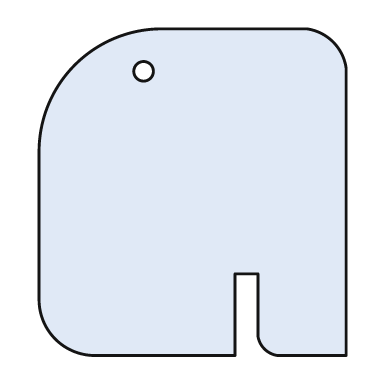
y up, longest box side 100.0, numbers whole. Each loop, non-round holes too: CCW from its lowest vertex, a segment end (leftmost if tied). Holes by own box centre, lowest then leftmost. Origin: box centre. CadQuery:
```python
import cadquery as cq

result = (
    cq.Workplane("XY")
    .moveTo(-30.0, -50.0)
    .lineTo(13.0, -50.0)
    .lineTo(13.0, -25.0)
    .lineTo(20.0, -25.0)
    .lineTo(20.0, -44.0)
    .threePointArc((22.0, -48.0), (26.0, -50.0))
    .lineTo(47.0, -50.0)
    .lineTo(47.0, 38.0)
    .threePointArc((43.0, 46.0), (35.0, 50.0))
    .lineTo(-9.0, 50.0)
    .threePointArc((-36.0, 39.0), (-47.0, 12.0))
    .lineTo(-47.0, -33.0)
    .threePointArc((-42.0, -45.0), (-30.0, -50.0))
    .close()
    .moveTo(-15.0, 37.0)
    .circle(3.0)
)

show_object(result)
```